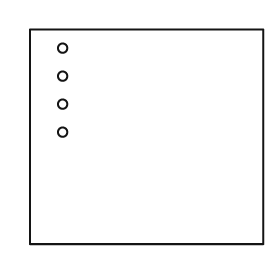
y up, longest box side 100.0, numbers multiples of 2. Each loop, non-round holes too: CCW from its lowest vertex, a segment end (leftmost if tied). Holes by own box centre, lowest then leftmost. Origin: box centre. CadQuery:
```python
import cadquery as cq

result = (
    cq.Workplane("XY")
    .moveTo(-50.0, -46.0)
    .lineTo(50.0, -46.0)
    .lineTo(50.0, 46.0)
    .lineTo(-50.0, 46.0)
    .close()
    .moveTo(-36.0, 2.0)
    .circle(2.0)
    .moveTo(-36.0, 14.0)
    .circle(2.0)
    .moveTo(-36.0, 26.0)
    .circle(2.0)
    .moveTo(-36.0, 38.0)
    .circle(2.0)
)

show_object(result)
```